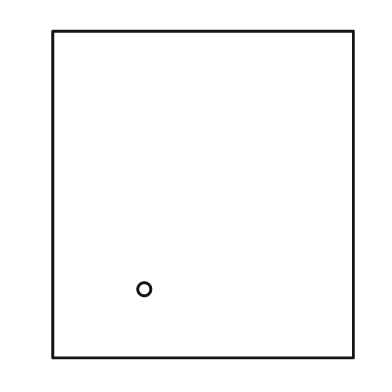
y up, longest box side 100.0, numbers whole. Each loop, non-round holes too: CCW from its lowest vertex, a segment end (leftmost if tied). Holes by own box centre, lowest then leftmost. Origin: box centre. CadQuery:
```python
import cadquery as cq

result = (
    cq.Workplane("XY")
    .moveTo(-46.0, -50.0)
    .lineTo(46.0, -50.0)
    .lineTo(46.0, 50.0)
    .lineTo(-46.0, 50.0)
    .close()
    .moveTo(-18.0, -29.0)
    .circle(2.0)
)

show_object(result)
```